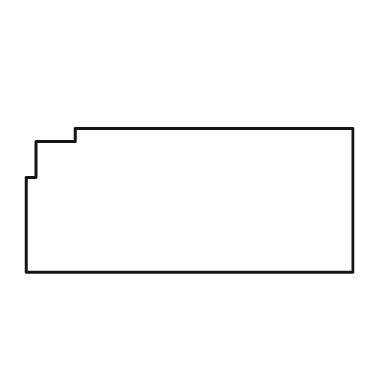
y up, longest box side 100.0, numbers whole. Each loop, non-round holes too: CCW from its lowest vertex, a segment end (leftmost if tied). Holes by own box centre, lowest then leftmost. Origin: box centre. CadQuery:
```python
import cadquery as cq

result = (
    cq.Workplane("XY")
    .moveTo(-50.0, -22.0)
    .lineTo(50.0, -22.0)
    .lineTo(50.0, 22.0)
    .lineTo(-35.0, 22.0)
    .lineTo(-35.0, 18.0)
    .lineTo(-47.0, 18.0)
    .lineTo(-47.0, 7.0)
    .lineTo(-50.0, 7.0)
    .close()
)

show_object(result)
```